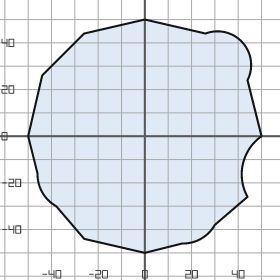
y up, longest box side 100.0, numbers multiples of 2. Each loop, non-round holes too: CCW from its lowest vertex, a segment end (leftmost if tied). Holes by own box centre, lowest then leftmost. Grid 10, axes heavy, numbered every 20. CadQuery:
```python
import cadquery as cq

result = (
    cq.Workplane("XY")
    .moveTo(0.0, -50.0)
    .lineTo(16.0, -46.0)
    .threePointArc((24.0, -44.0), (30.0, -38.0))
    .lineTo(44.0, -26.0)
    .threePointArc((42.0, -12.0), (50.0, 0.0))
    .lineTo(44.0, 24.0)
    .threePointArc((42.0, 40.0), (26.0, 44.0))
    .lineTo(0.0, 50.0)
    .lineTo(-26.0, 44.0)
    .lineTo(-44.0, 26.0)
    .lineTo(-50.0, 0.0)
    .lineTo(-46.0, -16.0)
    .threePointArc((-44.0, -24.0), (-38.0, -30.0))
    .lineTo(-26.0, -44.0)
    .close()
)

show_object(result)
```